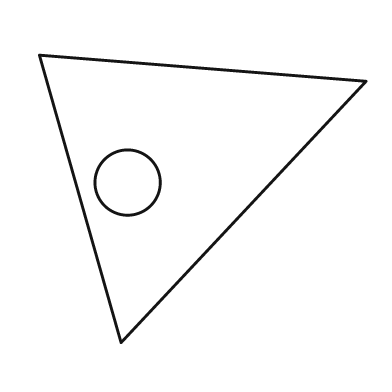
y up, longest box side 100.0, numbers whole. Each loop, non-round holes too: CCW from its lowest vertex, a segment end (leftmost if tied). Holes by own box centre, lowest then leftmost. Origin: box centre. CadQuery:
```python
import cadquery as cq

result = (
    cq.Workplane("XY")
    .moveTo(-25.0, -44.0)
    .lineTo(50.0, 36.0)
    .lineTo(-50.0, 44.0)
    .close()
    .moveTo(-23.0, 5.0)
    .circle(10.0)
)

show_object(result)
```